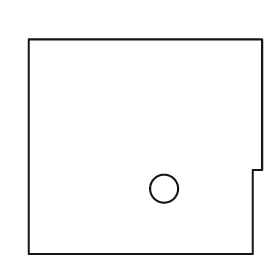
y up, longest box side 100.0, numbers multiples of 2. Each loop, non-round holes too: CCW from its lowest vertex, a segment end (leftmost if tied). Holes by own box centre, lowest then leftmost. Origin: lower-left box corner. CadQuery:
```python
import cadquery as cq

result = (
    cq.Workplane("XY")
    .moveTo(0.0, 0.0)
    .lineTo(96.0, 0.0)
    .lineTo(96.0, 36.0)
    .lineTo(100.0, 36.0)
    .lineTo(100.0, 92.0)
    .lineTo(0.0, 92.0)
    .close()
    .moveTo(58.0, 28.0)
    .circle(6.0)
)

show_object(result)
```